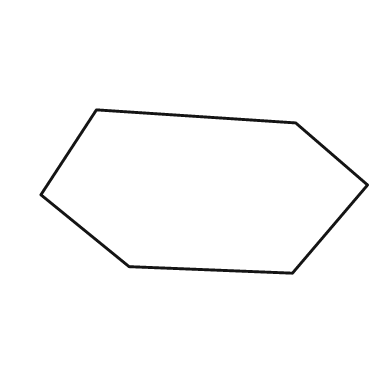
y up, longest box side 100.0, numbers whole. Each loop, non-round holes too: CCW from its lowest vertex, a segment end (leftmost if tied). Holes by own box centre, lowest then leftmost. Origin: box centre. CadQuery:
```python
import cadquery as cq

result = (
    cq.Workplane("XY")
    .moveTo(27.0, -25.0)
    .lineTo(50.0, 2.0)
    .lineTo(28.0, 21.0)
    .lineTo(-33.0, 25.0)
    .lineTo(-50.0, -1.0)
    .lineTo(-23.0, -23.0)
    .close()
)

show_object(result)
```